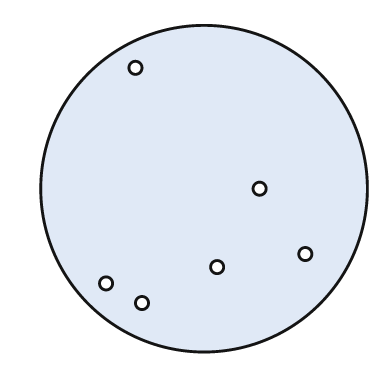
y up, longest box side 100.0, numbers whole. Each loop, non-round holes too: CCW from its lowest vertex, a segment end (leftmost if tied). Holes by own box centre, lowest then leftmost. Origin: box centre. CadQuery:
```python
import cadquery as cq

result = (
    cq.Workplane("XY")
    .moveTo(0.0, 0.0)
    .circle(50.0)
    .moveTo(-19.0, -35.0)
    .circle(2.0)
    .moveTo(-30.0, -29.0)
    .circle(2.0)
    .moveTo(4.0, -24.0)
    .circle(2.0)
    .moveTo(31.0, -20.0)
    .circle(2.0)
    .moveTo(17.0, 0.0)
    .circle(2.0)
    .moveTo(-21.0, 37.0)
    .circle(2.0)
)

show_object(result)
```